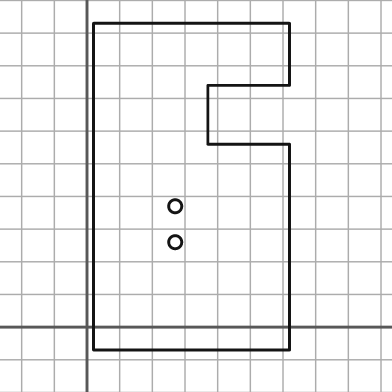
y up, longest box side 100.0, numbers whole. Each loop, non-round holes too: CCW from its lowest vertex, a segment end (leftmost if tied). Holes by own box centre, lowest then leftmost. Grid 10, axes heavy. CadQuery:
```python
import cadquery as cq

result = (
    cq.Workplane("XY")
    .moveTo(2.0, -7.0)
    .lineTo(62.0, -7.0)
    .lineTo(62.0, 56.0)
    .lineTo(37.0, 56.0)
    .lineTo(37.0, 74.0)
    .lineTo(62.0, 74.0)
    .lineTo(62.0, 93.0)
    .lineTo(2.0, 93.0)
    .close()
    .moveTo(27.0, 26.0)
    .circle(2.0)
    .moveTo(27.0, 37.0)
    .circle(2.0)
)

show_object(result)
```